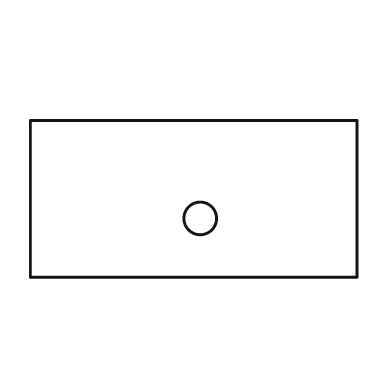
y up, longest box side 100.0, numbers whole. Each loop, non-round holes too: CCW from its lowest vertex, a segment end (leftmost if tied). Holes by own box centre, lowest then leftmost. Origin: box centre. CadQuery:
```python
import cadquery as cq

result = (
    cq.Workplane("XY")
    .moveTo(-50.0, -24.0)
    .lineTo(50.0, -24.0)
    .lineTo(50.0, 24.0)
    .lineTo(-50.0, 24.0)
    .close()
    .moveTo(2.0, -6.0)
    .circle(5.0)
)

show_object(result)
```